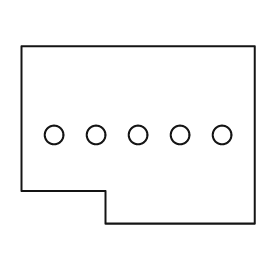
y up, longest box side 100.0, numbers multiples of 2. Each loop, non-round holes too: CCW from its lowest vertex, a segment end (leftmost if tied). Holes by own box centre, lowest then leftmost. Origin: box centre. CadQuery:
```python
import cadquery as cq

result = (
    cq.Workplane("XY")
    .moveTo(-14.0, -38.0)
    .lineTo(50.0, -38.0)
    .lineTo(50.0, 38.0)
    .lineTo(-50.0, 38.0)
    .lineTo(-50.0, -24.0)
    .lineTo(-14.0, -24.0)
    .close()
    .moveTo(-36.0, 0.0)
    .circle(4.0)
    .moveTo(-18.0, 0.0)
    .circle(4.0)
    .moveTo(0.0, 0.0)
    .circle(4.0)
    .moveTo(18.0, 0.0)
    .circle(4.0)
    .moveTo(36.0, 0.0)
    .circle(4.0)
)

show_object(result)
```